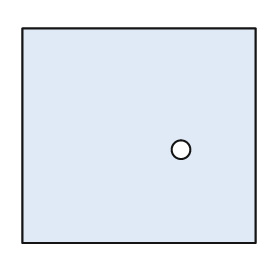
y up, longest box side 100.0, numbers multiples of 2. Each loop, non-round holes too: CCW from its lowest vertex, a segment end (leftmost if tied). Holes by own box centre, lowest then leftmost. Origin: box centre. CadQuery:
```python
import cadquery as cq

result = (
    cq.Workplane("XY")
    .moveTo(-50.0, -46.0)
    .lineTo(50.0, -46.0)
    .lineTo(50.0, 46.0)
    .lineTo(-50.0, 46.0)
    .close()
    .moveTo(18.0, -6.0)
    .circle(4.0)
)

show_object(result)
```